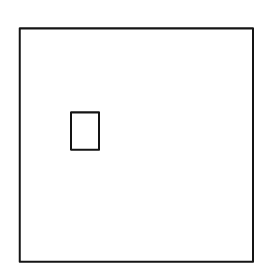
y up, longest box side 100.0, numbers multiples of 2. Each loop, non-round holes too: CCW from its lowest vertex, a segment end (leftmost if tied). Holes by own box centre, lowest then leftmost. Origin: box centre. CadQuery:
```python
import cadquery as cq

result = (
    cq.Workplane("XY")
    .moveTo(-50.0, -50.0)
    .lineTo(50.0, -50.0)
    .lineTo(50.0, 50.0)
    .lineTo(-50.0, 50.0)
    .close()
    .moveTo(-28.0, -2.0)
    .lineTo(-16.0, -2.0)
    .lineTo(-16.0, 14.0)
    .lineTo(-28.0, 14.0)
    .close()
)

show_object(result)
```